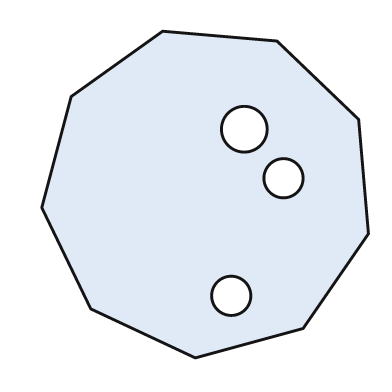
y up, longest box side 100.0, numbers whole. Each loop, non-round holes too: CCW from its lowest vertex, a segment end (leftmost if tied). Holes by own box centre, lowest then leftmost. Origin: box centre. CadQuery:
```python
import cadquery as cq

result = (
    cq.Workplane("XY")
    .moveTo(-3.0, -50.0)
    .lineTo(30.0, -41.0)
    .lineTo(50.0, -12.0)
    .lineTo(47.0, 23.0)
    .lineTo(22.0, 47.0)
    .lineTo(-13.0, 50.0)
    .lineTo(-41.0, 30.0)
    .lineTo(-50.0, -4.0)
    .lineTo(-35.0, -35.0)
    .close()
    .moveTo(8.0, -31.0)
    .circle(6.0)
    .moveTo(24.0, 5.0)
    .circle(6.0)
    .moveTo(12.0, 20.0)
    .circle(7.0)
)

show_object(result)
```